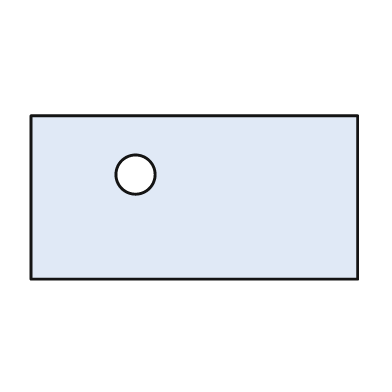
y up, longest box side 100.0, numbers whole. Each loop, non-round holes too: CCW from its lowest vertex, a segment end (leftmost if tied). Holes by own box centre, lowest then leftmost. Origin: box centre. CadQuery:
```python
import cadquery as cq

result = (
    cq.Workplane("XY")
    .moveTo(-50.0, -25.0)
    .lineTo(50.0, -25.0)
    .lineTo(50.0, 25.0)
    .lineTo(-50.0, 25.0)
    .close()
    .moveTo(-18.0, 7.0)
    .circle(6.0)
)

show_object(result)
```